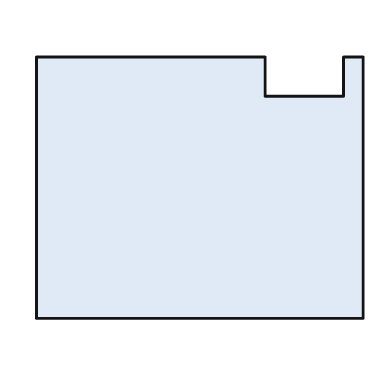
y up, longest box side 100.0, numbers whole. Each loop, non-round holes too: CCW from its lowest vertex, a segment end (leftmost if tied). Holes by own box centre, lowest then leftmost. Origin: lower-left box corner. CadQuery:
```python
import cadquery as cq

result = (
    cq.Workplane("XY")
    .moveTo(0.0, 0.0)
    .lineTo(100.0, 0.0)
    .lineTo(100.0, 80.0)
    .lineTo(94.0, 80.0)
    .lineTo(94.0, 68.0)
    .lineTo(70.0, 68.0)
    .lineTo(70.0, 80.0)
    .lineTo(0.0, 80.0)
    .close()
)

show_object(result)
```